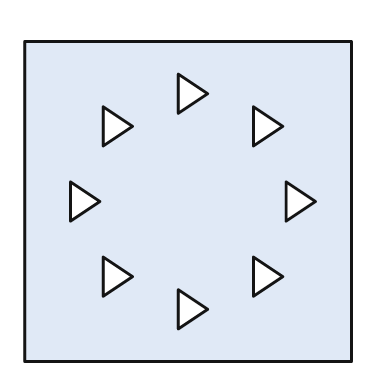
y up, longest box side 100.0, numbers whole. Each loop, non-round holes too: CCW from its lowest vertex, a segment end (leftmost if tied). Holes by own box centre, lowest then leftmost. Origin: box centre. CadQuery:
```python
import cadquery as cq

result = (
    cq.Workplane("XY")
    .moveTo(-50.0, -49.0)
    .lineTo(50.0, -49.0)
    .lineTo(50.0, 49.0)
    .lineTo(-50.0, 49.0)
    .close()
    .moveTo(-3.0, -39.0)
    .lineTo(6.0, -33.0)
    .lineTo(-3.0, -27.0)
    .close()
    .moveTo(-26.0, -29.0)
    .lineTo(-17.0, -23.0)
    .lineTo(-26.0, -17.0)
    .close()
    .moveTo(20.0, -29.0)
    .lineTo(29.0, -23.0)
    .lineTo(20.0, -17.0)
    .close()
    .moveTo(-36.0, -6.0)
    .lineTo(-27.0, 0.0)
    .lineTo(-36.0, 6.0)
    .close()
    .moveTo(30.0, -6.0)
    .lineTo(39.0, 0.0)
    .lineTo(30.0, 6.0)
    .close()
    .moveTo(-26.0, 17.0)
    .lineTo(-17.0, 23.0)
    .lineTo(-26.0, 29.0)
    .close()
    .moveTo(20.0, 17.0)
    .lineTo(29.0, 23.0)
    .lineTo(20.0, 29.0)
    .close()
    .moveTo(-3.0, 27.0)
    .lineTo(6.0, 33.0)
    .lineTo(-3.0, 39.0)
    .close()
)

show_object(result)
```